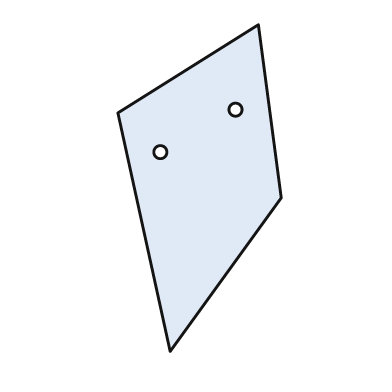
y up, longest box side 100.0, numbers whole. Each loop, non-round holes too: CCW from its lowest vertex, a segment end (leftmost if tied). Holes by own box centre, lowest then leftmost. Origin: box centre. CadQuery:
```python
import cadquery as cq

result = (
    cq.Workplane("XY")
    .moveTo(-9.0, -50.0)
    .lineTo(25.0, -3.0)
    .lineTo(18.0, 50.0)
    .lineTo(-25.0, 23.0)
    .close()
    .moveTo(-12.0, 11.0)
    .circle(2.0)
    .moveTo(11.0, 24.0)
    .circle(2.0)
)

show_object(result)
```